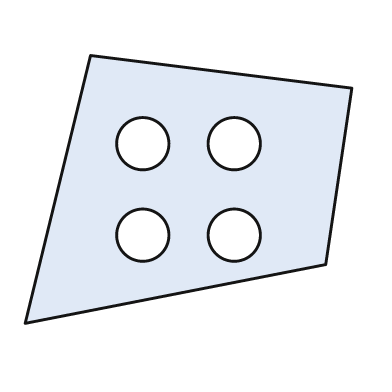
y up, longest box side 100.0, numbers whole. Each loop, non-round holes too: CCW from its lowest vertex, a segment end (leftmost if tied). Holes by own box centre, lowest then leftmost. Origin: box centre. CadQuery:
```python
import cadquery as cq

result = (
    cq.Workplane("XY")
    .moveTo(-50.0, -41.0)
    .lineTo(42.0, -23.0)
    .lineTo(50.0, 31.0)
    .lineTo(-30.0, 41.0)
    .close()
    .moveTo(-14.0, -14.0)
    .circle(8.0)
    .moveTo(14.0, -14.0)
    .circle(8.0)
    .moveTo(-14.0, 14.0)
    .circle(8.0)
    .moveTo(14.0, 14.0)
    .circle(8.0)
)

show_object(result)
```